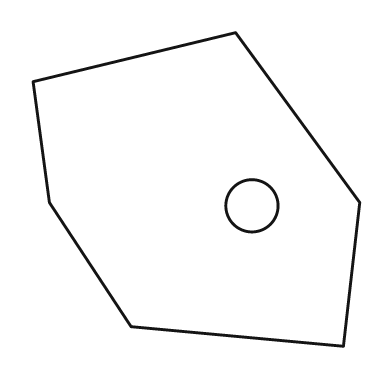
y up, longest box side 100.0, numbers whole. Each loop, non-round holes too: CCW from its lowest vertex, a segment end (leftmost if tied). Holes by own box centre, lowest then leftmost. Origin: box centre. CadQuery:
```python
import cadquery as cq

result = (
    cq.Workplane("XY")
    .moveTo(45.0, -48.0)
    .lineTo(50.0, -4.0)
    .lineTo(12.0, 48.0)
    .lineTo(-50.0, 33.0)
    .lineTo(-45.0, -4.0)
    .lineTo(-20.0, -42.0)
    .close()
    .moveTo(17.0, -5.0)
    .circle(8.0)
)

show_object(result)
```